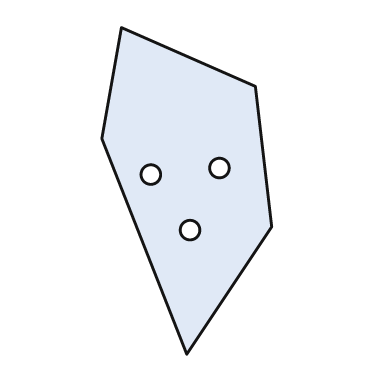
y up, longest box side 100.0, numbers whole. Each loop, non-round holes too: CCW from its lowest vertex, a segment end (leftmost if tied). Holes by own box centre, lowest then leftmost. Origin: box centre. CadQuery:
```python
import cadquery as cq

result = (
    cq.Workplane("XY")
    .moveTo(0.0, -50.0)
    .lineTo(26.0, -11.0)
    .lineTo(21.0, 32.0)
    .lineTo(-20.0, 50.0)
    .lineTo(-26.0, 16.0)
    .close()
    .moveTo(1.0, -12.0)
    .circle(3.0)
    .moveTo(-11.0, 5.0)
    .circle(3.0)
    .moveTo(10.0, 7.0)
    .circle(3.0)
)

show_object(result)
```